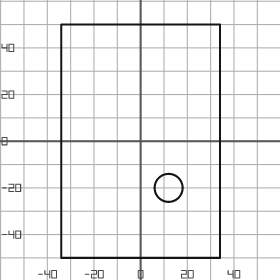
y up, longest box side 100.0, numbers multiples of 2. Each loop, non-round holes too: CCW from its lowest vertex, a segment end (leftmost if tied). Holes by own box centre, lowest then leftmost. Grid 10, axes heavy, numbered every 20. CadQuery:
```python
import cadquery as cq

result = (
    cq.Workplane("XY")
    .moveTo(-34.0, -50.0)
    .lineTo(34.0, -50.0)
    .lineTo(34.0, 50.0)
    .lineTo(-34.0, 50.0)
    .close()
    .moveTo(12.0, -20.0)
    .circle(6.0)
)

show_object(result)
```